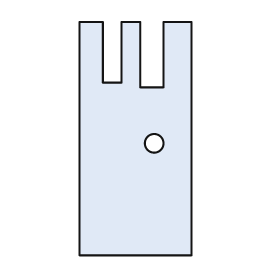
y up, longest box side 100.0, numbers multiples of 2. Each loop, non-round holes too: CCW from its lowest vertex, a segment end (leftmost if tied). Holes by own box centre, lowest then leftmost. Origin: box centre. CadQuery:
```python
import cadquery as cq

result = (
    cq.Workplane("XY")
    .moveTo(-24.0, -50.0)
    .lineTo(24.0, -50.0)
    .lineTo(24.0, 50.0)
    .lineTo(12.0, 50.0)
    .lineTo(12.0, 22.0)
    .lineTo(2.0, 22.0)
    .lineTo(2.0, 50.0)
    .lineTo(-6.0, 50.0)
    .lineTo(-6.0, 24.0)
    .lineTo(-14.0, 24.0)
    .lineTo(-14.0, 50.0)
    .lineTo(-24.0, 50.0)
    .close()
    .moveTo(8.0, -2.0)
    .circle(4.0)
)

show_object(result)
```